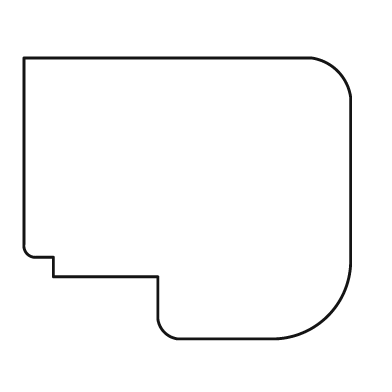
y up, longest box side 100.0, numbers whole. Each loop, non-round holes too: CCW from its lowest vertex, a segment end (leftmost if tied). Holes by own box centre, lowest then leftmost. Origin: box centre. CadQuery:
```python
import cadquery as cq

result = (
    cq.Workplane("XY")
    .moveTo(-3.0, -43.0)
    .lineTo(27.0, -43.0)
    .threePointArc((43.0, -36.0), (50.0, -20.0))
    .lineTo(50.0, 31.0)
    .threePointArc((46.0, 39.0), (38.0, 43.0))
    .lineTo(-50.0, 43.0)
    .lineTo(-50.0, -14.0)
    .threePointArc((-49.0, -17.0), (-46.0, -18.0))
    .lineTo(-41.0, -18.0)
    .lineTo(-41.0, -24.0)
    .lineTo(-9.0, -24.0)
    .lineTo(-9.0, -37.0)
    .threePointArc((-7.0, -41.0), (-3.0, -43.0))
    .close()
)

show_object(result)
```